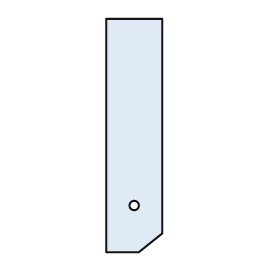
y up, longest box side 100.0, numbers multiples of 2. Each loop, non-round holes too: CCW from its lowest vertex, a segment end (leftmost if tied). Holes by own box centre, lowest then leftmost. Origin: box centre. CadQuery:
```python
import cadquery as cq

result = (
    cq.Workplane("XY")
    .moveTo(-12.0, -50.0)
    .lineTo(2.0, -50.0)
    .lineTo(12.0, -42.0)
    .lineTo(12.0, 50.0)
    .lineTo(-12.0, 50.0)
    .close()
    .moveTo(0.0, -30.0)
    .circle(2.0)
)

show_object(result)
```